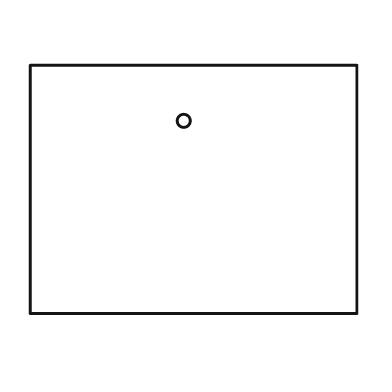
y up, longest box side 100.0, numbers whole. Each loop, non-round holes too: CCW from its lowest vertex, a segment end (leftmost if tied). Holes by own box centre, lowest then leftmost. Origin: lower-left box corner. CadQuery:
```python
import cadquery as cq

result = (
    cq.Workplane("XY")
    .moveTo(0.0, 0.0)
    .lineTo(100.0, 0.0)
    .lineTo(100.0, 76.0)
    .lineTo(0.0, 76.0)
    .close()
    .moveTo(47.0, 59.0)
    .circle(2.0)
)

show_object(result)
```